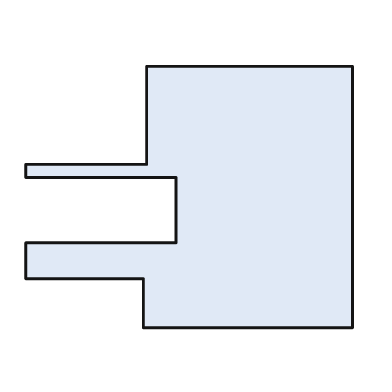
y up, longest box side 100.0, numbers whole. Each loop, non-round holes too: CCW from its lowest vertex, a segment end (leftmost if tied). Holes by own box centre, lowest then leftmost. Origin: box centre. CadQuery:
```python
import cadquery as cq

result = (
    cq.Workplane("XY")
    .moveTo(-14.0, -40.0)
    .lineTo(50.0, -40.0)
    .lineTo(50.0, 40.0)
    .lineTo(-13.0, 40.0)
    .lineTo(-13.0, 10.0)
    .lineTo(-50.0, 10.0)
    .lineTo(-50.0, 6.0)
    .lineTo(-4.0, 6.0)
    .lineTo(-4.0, -14.0)
    .lineTo(-50.0, -14.0)
    .lineTo(-50.0, -25.0)
    .lineTo(-14.0, -25.0)
    .close()
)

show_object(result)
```